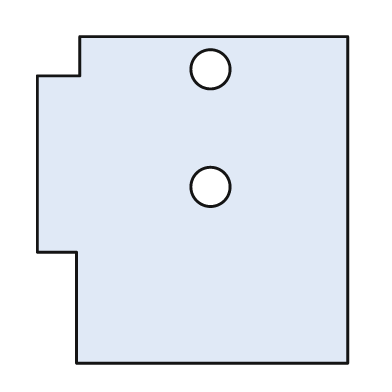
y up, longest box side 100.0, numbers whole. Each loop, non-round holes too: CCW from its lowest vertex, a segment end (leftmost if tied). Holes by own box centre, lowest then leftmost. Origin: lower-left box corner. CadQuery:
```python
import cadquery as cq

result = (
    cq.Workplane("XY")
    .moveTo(12.0, 0.0)
    .lineTo(95.0, 0.0)
    .lineTo(95.0, 100.0)
    .lineTo(13.0, 100.0)
    .lineTo(13.0, 88.0)
    .lineTo(0.0, 88.0)
    .lineTo(0.0, 34.0)
    .lineTo(12.0, 34.0)
    .close()
    .moveTo(53.0, 54.0)
    .circle(6.0)
    .moveTo(53.0, 90.0)
    .circle(6.0)
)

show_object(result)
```